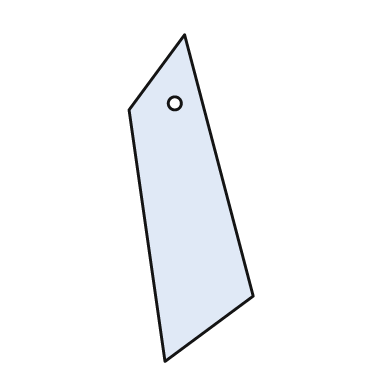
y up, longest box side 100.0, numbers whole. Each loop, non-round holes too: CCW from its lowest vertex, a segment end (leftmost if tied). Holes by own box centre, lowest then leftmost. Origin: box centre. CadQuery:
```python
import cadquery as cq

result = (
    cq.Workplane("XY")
    .moveTo(-8.0, -50.0)
    .lineTo(19.0, -30.0)
    .lineTo(-2.0, 50.0)
    .lineTo(-19.0, 27.0)
    .close()
    .moveTo(-5.0, 29.0)
    .circle(2.0)
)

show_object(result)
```